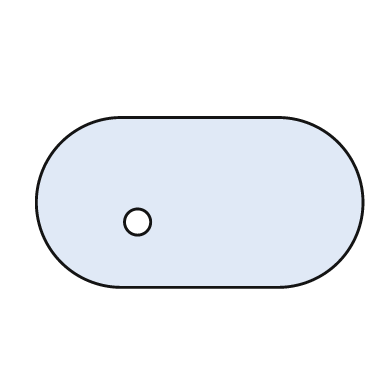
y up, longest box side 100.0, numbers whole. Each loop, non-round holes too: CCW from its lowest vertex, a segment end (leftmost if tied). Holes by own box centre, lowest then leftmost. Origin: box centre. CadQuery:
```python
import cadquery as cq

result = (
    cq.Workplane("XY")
    .moveTo(-24.0, -26.0)
    .lineTo(24.0, -26.0)
    .threePointArc((50.0, 0.0), (24.0, 26.0))
    .lineTo(-24.0, 26.0)
    .threePointArc((-50.0, 0.0), (-24.0, -26.0))
    .close()
    .moveTo(-19.0, -6.0)
    .circle(4.0)
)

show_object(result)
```